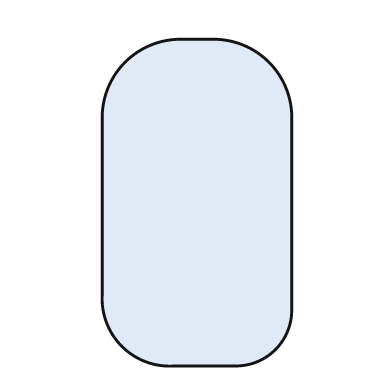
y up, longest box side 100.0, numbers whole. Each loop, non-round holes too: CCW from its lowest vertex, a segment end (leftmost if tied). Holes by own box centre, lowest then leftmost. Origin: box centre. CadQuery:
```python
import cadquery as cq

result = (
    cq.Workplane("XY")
    .moveTo(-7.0, -50.0)
    .lineTo(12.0, -50.0)
    .threePointArc((24.0, -45.0), (29.0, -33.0))
    .lineTo(29.0, 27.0)
    .threePointArc((22.0, 43.0), (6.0, 50.0))
    .lineTo(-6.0, 50.0)
    .threePointArc((-22.0, 43.0), (-29.0, 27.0))
    .lineTo(-29.0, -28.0)
    .threePointArc((-23.0, -44.0), (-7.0, -50.0))
    .close()
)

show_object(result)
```